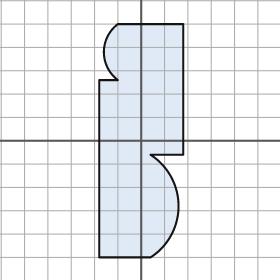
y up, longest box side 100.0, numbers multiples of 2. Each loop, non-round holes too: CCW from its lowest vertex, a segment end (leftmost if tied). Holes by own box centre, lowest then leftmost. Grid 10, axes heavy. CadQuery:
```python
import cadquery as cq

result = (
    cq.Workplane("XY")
    .moveTo(-18.0, -50.0)
    .lineTo(4.0, -50.0)
    .threePointArc((16.0, -28.0), (4.0, -6.0))
    .lineTo(18.0, -6.0)
    .lineTo(18.0, 50.0)
    .lineTo(-10.0, 50.0)
    .threePointArc((-16.0, 38.0), (-10.0, 26.0))
    .lineTo(-18.0, 26.0)
    .close()
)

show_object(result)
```